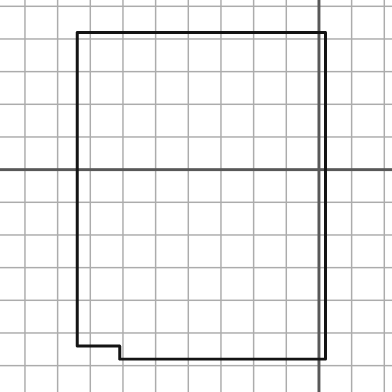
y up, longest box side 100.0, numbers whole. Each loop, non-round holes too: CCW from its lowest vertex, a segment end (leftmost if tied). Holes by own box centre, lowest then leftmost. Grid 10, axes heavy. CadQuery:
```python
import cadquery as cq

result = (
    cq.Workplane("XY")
    .moveTo(-61.0, -58.0)
    .lineTo(2.0, -58.0)
    .lineTo(2.0, 42.0)
    .lineTo(-74.0, 42.0)
    .lineTo(-74.0, -54.0)
    .lineTo(-61.0, -54.0)
    .close()
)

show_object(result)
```